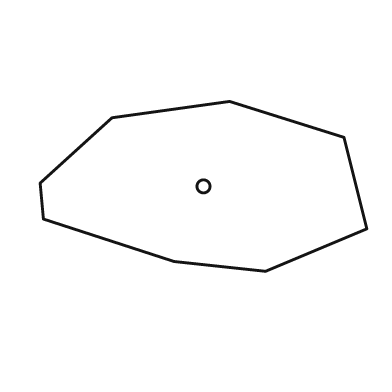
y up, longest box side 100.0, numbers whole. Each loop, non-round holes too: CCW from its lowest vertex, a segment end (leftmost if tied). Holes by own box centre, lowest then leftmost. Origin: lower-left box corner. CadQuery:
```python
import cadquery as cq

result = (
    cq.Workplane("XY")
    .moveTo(69.0, 0.0)
    .lineTo(100.0, 13.0)
    .lineTo(93.0, 41.0)
    .lineTo(58.0, 52.0)
    .lineTo(22.0, 47.0)
    .lineTo(0.0, 27.0)
    .lineTo(1.0, 16.0)
    .lineTo(41.0, 3.0)
    .close()
    .moveTo(50.0, 26.0)
    .circle(2.0)
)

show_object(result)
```